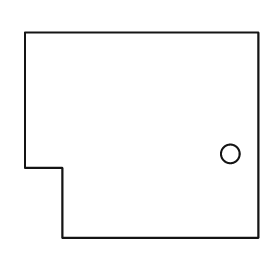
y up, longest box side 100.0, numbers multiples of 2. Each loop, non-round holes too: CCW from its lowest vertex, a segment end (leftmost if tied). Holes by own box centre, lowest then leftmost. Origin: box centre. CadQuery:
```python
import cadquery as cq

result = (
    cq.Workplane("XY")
    .moveTo(-34.0, -44.0)
    .lineTo(50.0, -44.0)
    .lineTo(50.0, 44.0)
    .lineTo(-50.0, 44.0)
    .lineTo(-50.0, -14.0)
    .lineTo(-34.0, -14.0)
    .close()
    .moveTo(38.0, -8.0)
    .circle(4.0)
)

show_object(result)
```